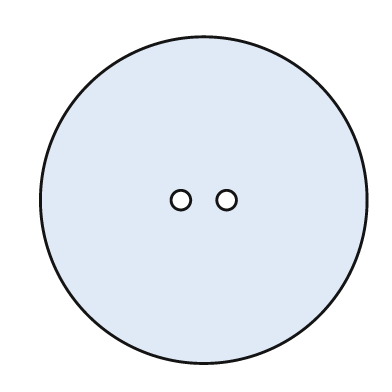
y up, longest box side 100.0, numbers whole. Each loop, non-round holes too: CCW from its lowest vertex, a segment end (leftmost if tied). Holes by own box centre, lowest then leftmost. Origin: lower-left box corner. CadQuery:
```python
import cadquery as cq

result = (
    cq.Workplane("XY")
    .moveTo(50.0, 50.0)
    .circle(50.0)
    .moveTo(43.0, 50.0)
    .circle(3.0)
    .moveTo(57.0, 50.0)
    .circle(3.0)
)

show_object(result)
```